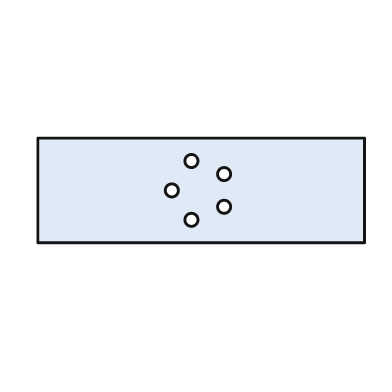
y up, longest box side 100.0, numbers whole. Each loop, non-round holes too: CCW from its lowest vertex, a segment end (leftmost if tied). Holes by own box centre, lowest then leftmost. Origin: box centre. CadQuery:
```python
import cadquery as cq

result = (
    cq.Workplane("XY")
    .moveTo(-50.0, -16.0)
    .lineTo(50.0, -16.0)
    .lineTo(50.0, 16.0)
    .lineTo(-50.0, 16.0)
    .close()
    .moveTo(-3.0, -9.0)
    .circle(2.0)
    .moveTo(7.0, -5.0)
    .circle(2.0)
    .moveTo(-9.0, 0.0)
    .circle(2.0)
    .moveTo(7.0, 5.0)
    .circle(2.0)
    .moveTo(-3.0, 9.0)
    .circle(2.0)
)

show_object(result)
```